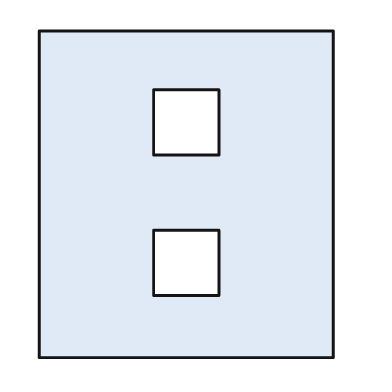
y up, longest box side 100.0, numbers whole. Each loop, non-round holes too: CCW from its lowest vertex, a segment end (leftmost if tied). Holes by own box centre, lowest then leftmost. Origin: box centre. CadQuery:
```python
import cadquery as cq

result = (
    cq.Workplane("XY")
    .moveTo(-45.0, -50.0)
    .lineTo(45.0, -50.0)
    .lineTo(45.0, 50.0)
    .lineTo(-45.0, 50.0)
    .close()
    .moveTo(-10.0, -31.0)
    .lineTo(10.0, -31.0)
    .lineTo(10.0, -11.0)
    .lineTo(-10.0, -11.0)
    .close()
    .moveTo(-10.0, 12.0)
    .lineTo(10.0, 12.0)
    .lineTo(10.0, 32.0)
    .lineTo(-10.0, 32.0)
    .close()
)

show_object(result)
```